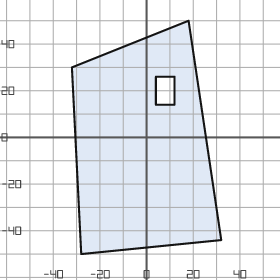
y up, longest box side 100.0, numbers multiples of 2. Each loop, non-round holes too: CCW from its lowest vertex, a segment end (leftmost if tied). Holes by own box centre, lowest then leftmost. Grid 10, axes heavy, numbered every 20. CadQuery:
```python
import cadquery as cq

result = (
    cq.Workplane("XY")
    .moveTo(-28.0, -50.0)
    .lineTo(32.0, -44.0)
    .lineTo(18.0, 50.0)
    .lineTo(-32.0, 30.0)
    .close()
    .moveTo(4.0, 14.0)
    .lineTo(12.0, 14.0)
    .lineTo(12.0, 26.0)
    .lineTo(4.0, 26.0)
    .close()
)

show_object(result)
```